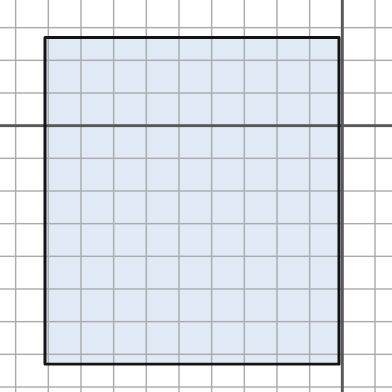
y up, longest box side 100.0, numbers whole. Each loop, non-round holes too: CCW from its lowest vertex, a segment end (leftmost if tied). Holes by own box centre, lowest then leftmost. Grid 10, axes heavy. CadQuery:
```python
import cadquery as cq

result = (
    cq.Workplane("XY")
    .moveTo(-91.0, -73.0)
    .lineTo(-1.0, -73.0)
    .lineTo(-1.0, 27.0)
    .lineTo(-91.0, 27.0)
    .close()
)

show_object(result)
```